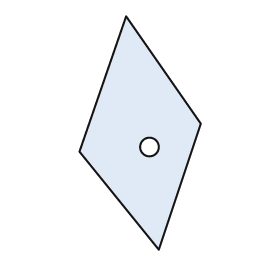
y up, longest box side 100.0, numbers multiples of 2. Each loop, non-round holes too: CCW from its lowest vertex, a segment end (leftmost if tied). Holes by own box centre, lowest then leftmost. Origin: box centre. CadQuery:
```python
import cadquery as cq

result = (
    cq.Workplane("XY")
    .moveTo(8.0, -50.0)
    .lineTo(26.0, 4.0)
    .lineTo(-6.0, 50.0)
    .lineTo(-26.0, -8.0)
    .close()
    .moveTo(4.0, -6.0)
    .circle(4.0)
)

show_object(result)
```